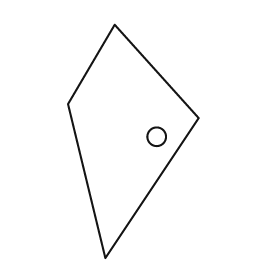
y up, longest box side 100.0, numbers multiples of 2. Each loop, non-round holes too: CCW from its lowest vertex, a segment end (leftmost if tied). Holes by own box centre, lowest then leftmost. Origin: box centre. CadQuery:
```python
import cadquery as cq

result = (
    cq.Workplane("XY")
    .moveTo(-12.0, -50.0)
    .lineTo(28.0, 10.0)
    .lineTo(-8.0, 50.0)
    .lineTo(-28.0, 16.0)
    .close()
    .moveTo(10.0, 2.0)
    .circle(4.0)
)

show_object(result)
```